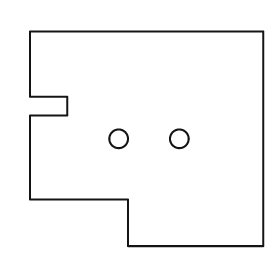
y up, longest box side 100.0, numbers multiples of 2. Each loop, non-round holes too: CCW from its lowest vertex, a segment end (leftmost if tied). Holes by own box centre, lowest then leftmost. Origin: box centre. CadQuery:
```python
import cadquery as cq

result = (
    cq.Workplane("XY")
    .moveTo(-8.0, -46.0)
    .lineTo(50.0, -46.0)
    .lineTo(50.0, 46.0)
    .lineTo(-50.0, 46.0)
    .lineTo(-50.0, 18.0)
    .lineTo(-34.0, 18.0)
    .lineTo(-34.0, 10.0)
    .lineTo(-50.0, 10.0)
    .lineTo(-50.0, -26.0)
    .lineTo(-8.0, -26.0)
    .close()
    .moveTo(-12.0, 0.0)
    .circle(4.0)
    .moveTo(14.0, 0.0)
    .circle(4.0)
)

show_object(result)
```